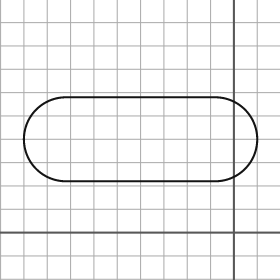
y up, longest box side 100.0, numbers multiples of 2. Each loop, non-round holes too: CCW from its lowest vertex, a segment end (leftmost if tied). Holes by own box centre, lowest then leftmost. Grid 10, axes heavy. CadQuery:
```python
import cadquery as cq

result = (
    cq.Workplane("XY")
    .moveTo(-72.0, 22.0)
    .lineTo(-8.0, 22.0)
    .threePointArc((10.0, 40.0), (-8.0, 58.0))
    .lineTo(-72.0, 58.0)
    .threePointArc((-90.0, 40.0), (-72.0, 22.0))
    .close()
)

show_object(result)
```